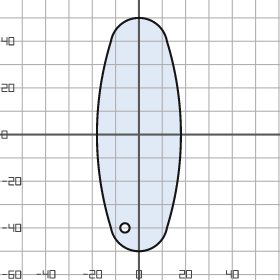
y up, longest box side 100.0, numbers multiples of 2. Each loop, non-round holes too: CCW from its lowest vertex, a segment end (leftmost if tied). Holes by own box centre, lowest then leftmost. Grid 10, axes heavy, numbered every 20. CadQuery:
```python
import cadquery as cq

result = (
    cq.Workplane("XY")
    .moveTo(-12.0, -40.0)
    .threePointArc((0.0, -50.0), (12.0, -40.0))
    .threePointArc((18.0, 0.0), (12.0, 40.0))
    .threePointArc((0.0, 50.0), (-12.0, 40.0))
    .threePointArc((-18.0, 0.0), (-12.0, -40.0))
    .close()
    .moveTo(-6.0, -40.0)
    .circle(2.0)
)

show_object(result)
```